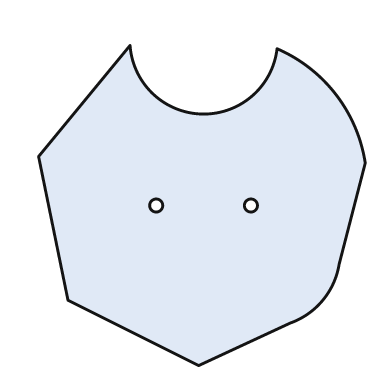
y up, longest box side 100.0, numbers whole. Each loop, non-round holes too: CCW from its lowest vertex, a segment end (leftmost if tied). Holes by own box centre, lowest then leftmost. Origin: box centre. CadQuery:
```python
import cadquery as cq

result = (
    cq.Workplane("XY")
    .moveTo(-1.0, -49.0)
    .lineTo(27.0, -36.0)
    .threePointArc((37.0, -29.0), (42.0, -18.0))
    .lineTo(50.0, 13.0)
    .threePointArc((41.0, 34.0), (23.0, 48.0))
    .threePointArc((0.0, 28.0), (-22.0, 49.0))
    .lineTo(-50.0, 15.0)
    .lineTo(-41.0, -29.0)
    .close()
    .moveTo(-14.0, 0.0)
    .circle(2.0)
    .moveTo(15.0, 0.0)
    .circle(2.0)
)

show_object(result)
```